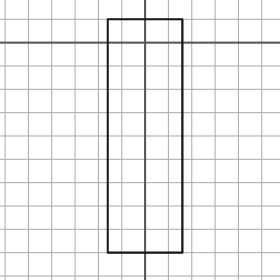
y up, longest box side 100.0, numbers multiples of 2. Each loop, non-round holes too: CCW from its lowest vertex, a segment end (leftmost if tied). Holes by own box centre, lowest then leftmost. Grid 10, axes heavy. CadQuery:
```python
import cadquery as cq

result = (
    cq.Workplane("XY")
    .moveTo(-16.0, -90.0)
    .lineTo(16.0, -90.0)
    .lineTo(16.0, 10.0)
    .lineTo(-16.0, 10.0)
    .close()
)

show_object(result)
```